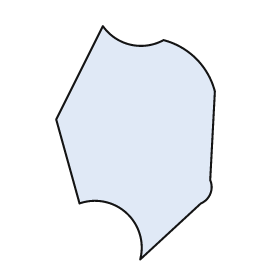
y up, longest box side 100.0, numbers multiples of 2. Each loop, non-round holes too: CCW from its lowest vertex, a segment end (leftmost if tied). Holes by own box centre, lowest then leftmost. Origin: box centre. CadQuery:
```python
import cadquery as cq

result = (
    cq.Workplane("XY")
    .moveTo(2.0, -50.0)
    .lineTo(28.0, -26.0)
    .threePointArc((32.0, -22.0), (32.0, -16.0))
    .lineTo(34.0, 22.0)
    .threePointArc((26.0, 36.0), (12.0, 44.0))
    .threePointArc((-2.0, 42.0), (-14.0, 50.0))
    .lineTo(-34.0, 10.0)
    .lineTo(-24.0, -26.0)
    .threePointArc((-4.0, -30.0), (2.0, -50.0))
    .close()
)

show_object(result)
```